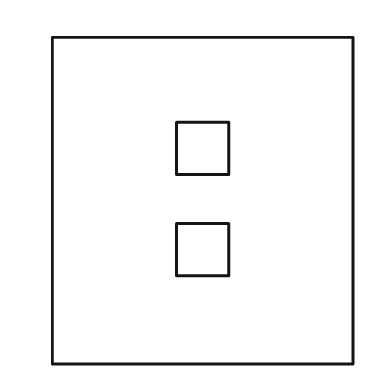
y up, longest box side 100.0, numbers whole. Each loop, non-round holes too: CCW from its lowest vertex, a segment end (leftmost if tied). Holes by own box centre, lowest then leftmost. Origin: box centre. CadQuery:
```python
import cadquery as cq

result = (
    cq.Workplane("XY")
    .moveTo(-46.0, -50.0)
    .lineTo(46.0, -50.0)
    .lineTo(46.0, 50.0)
    .lineTo(-46.0, 50.0)
    .close()
    .moveTo(-8.0, -23.0)
    .lineTo(8.0, -23.0)
    .lineTo(8.0, -7.0)
    .lineTo(-8.0, -7.0)
    .close()
    .moveTo(-8.0, 8.0)
    .lineTo(8.0, 8.0)
    .lineTo(8.0, 24.0)
    .lineTo(-8.0, 24.0)
    .close()
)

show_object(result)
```